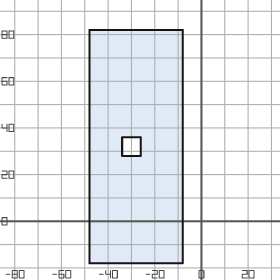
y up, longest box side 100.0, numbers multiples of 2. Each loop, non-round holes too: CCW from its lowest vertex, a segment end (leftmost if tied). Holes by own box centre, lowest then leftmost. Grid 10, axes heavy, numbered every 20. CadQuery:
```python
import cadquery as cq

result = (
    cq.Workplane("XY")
    .moveTo(-48.0, -18.0)
    .lineTo(-8.0, -18.0)
    .lineTo(-8.0, 82.0)
    .lineTo(-48.0, 82.0)
    .close()
    .moveTo(-34.0, 28.0)
    .lineTo(-26.0, 28.0)
    .lineTo(-26.0, 36.0)
    .lineTo(-34.0, 36.0)
    .close()
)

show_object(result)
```